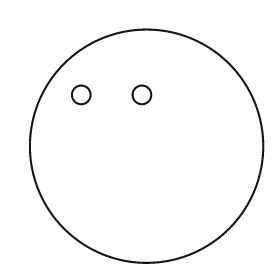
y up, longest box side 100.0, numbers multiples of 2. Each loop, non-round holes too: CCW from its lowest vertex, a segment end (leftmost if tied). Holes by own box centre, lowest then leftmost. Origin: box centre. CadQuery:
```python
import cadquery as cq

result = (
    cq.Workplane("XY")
    .moveTo(0.0, 0.0)
    .circle(50.0)
    .moveTo(-28.0, 22.0)
    .circle(4.0)
    .moveTo(-2.0, 22.0)
    .circle(4.0)
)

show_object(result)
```